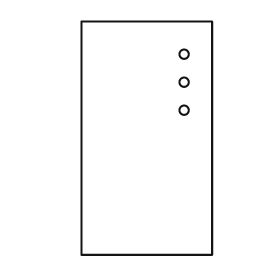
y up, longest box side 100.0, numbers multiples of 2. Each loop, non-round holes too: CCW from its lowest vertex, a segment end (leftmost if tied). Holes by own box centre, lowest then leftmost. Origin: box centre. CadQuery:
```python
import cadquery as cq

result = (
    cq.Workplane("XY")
    .moveTo(-28.0, -50.0)
    .lineTo(28.0, -50.0)
    .lineTo(28.0, 50.0)
    .lineTo(-28.0, 50.0)
    .close()
    .moveTo(16.0, 12.0)
    .circle(2.0)
    .moveTo(16.0, 24.0)
    .circle(2.0)
    .moveTo(16.0, 36.0)
    .circle(2.0)
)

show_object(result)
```